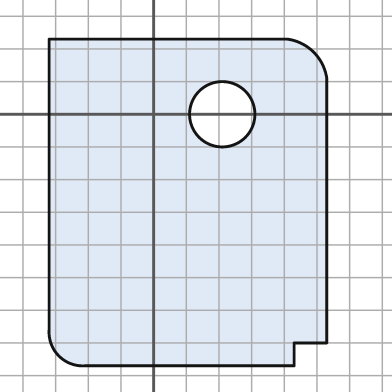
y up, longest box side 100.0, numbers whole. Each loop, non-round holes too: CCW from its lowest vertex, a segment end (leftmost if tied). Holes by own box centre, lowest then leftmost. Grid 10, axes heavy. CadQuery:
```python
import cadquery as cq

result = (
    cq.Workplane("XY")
    .moveTo(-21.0, -77.0)
    .lineTo(43.0, -77.0)
    .lineTo(43.0, -70.0)
    .lineTo(53.0, -70.0)
    .lineTo(53.0, 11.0)
    .threePointArc((49.0, 19.0), (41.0, 23.0))
    .lineTo(-32.0, 23.0)
    .lineTo(-32.0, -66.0)
    .threePointArc((-29.0, -74.0), (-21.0, -77.0))
    .close()
    .moveTo(21.0, 0.0)
    .circle(10.0)
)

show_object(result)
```